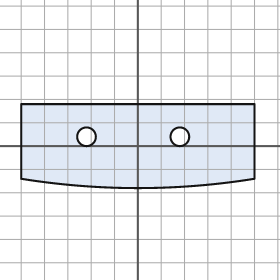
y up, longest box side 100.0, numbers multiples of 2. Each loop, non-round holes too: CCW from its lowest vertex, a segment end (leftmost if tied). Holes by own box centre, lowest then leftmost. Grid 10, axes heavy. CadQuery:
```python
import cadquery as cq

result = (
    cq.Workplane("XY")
    .moveTo(-50.0, -14.0)
    .threePointArc((0.0, -18.0), (50.0, -14.0))
    .lineTo(50.0, 18.0)
    .lineTo(-50.0, 18.0)
    .close()
    .moveTo(-22.0, 4.0)
    .circle(4.0)
    .moveTo(18.0, 4.0)
    .circle(4.0)
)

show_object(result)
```